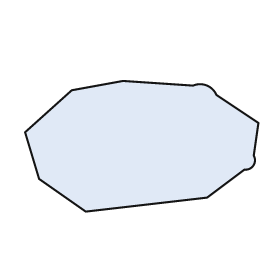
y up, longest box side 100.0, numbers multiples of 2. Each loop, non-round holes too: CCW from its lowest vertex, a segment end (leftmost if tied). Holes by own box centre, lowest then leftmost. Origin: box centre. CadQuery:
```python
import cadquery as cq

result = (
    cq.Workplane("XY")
    .moveTo(-24.0, -28.0)
    .lineTo(28.0, -22.0)
    .lineTo(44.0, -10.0)
    .threePointArc((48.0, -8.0), (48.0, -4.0))
    .lineTo(50.0, 10.0)
    .lineTo(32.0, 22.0)
    .threePointArc((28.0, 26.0), (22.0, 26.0))
    .lineTo(-8.0, 28.0)
    .lineTo(-30.0, 24.0)
    .lineTo(-50.0, 6.0)
    .lineTo(-44.0, -14.0)
    .close()
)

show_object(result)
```